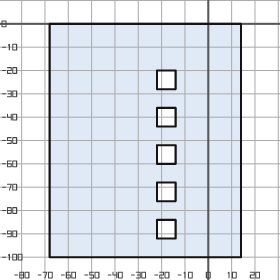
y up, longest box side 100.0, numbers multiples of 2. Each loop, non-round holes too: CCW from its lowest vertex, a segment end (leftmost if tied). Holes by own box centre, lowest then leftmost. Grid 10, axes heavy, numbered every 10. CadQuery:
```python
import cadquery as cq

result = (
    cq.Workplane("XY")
    .moveTo(-68.0, -100.0)
    .lineTo(14.0, -100.0)
    .lineTo(14.0, 0.0)
    .lineTo(-68.0, 0.0)
    .close()
    .moveTo(-22.0, -92.0)
    .lineTo(-14.0, -92.0)
    .lineTo(-14.0, -84.0)
    .lineTo(-22.0, -84.0)
    .close()
    .moveTo(-22.0, -76.0)
    .lineTo(-14.0, -76.0)
    .lineTo(-14.0, -68.0)
    .lineTo(-22.0, -68.0)
    .close()
    .moveTo(-22.0, -60.0)
    .lineTo(-14.0, -60.0)
    .lineTo(-14.0, -52.0)
    .lineTo(-22.0, -52.0)
    .close()
    .moveTo(-22.0, -44.0)
    .lineTo(-14.0, -44.0)
    .lineTo(-14.0, -36.0)
    .lineTo(-22.0, -36.0)
    .close()
    .moveTo(-22.0, -28.0)
    .lineTo(-14.0, -28.0)
    .lineTo(-14.0, -20.0)
    .lineTo(-22.0, -20.0)
    .close()
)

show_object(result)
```